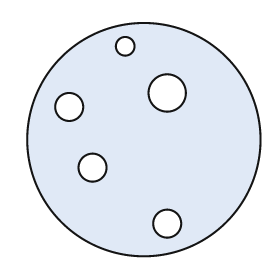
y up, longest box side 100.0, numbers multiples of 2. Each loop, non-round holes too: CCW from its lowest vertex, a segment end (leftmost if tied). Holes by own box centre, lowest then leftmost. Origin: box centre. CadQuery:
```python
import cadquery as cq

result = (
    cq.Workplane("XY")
    .moveTo(0.0, 0.0)
    .circle(50.0)
    .moveTo(10.0, -36.0)
    .circle(6.0)
    .moveTo(-22.0, -12.0)
    .circle(6.0)
    .moveTo(-32.0, 14.0)
    .circle(6.0)
    .moveTo(10.0, 20.0)
    .circle(8.0)
    .moveTo(-8.0, 40.0)
    .circle(4.0)
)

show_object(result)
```